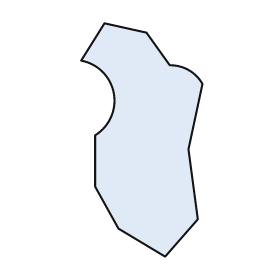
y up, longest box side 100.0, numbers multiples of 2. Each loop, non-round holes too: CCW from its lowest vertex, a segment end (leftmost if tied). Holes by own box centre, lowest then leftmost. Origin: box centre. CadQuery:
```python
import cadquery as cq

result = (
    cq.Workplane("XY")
    .moveTo(10.0, -50.0)
    .lineTo(24.0, -34.0)
    .lineTo(20.0, -4.0)
    .lineTo(26.0, 24.0)
    .threePointArc((20.0, 30.0), (12.0, 32.0))
    .lineTo(2.0, 46.0)
    .lineTo(-16.0, 50.0)
    .lineTo(-26.0, 34.0)
    .threePointArc((-12.0, 20.0), (-20.0, 2.0))
    .lineTo(-20.0, -20.0)
    .lineTo(-10.0, -38.0)
    .close()
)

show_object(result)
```